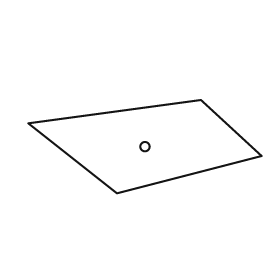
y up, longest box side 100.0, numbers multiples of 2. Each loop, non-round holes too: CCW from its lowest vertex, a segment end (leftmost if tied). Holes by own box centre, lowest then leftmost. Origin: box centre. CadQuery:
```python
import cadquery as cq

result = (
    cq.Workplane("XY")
    .moveTo(-12.0, -20.0)
    .lineTo(50.0, -4.0)
    .lineTo(24.0, 20.0)
    .lineTo(-50.0, 10.0)
    .close()
    .moveTo(0.0, 0.0)
    .circle(2.0)
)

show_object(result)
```